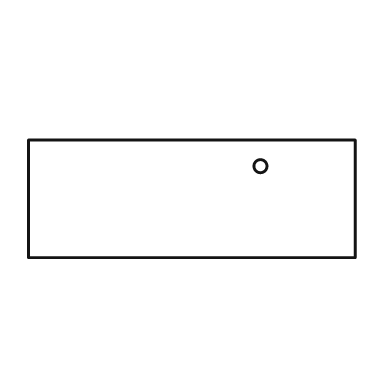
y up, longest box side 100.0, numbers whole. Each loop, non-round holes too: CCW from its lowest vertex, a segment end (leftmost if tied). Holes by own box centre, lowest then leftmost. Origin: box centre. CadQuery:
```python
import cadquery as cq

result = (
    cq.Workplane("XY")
    .moveTo(-50.0, -18.0)
    .lineTo(50.0, -18.0)
    .lineTo(50.0, 18.0)
    .lineTo(-50.0, 18.0)
    .close()
    .moveTo(21.0, 10.0)
    .circle(2.0)
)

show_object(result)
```